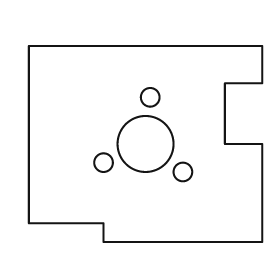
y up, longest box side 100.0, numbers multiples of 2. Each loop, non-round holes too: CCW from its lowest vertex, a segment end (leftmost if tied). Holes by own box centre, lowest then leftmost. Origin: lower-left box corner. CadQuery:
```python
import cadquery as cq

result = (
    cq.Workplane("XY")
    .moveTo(32.0, 0.0)
    .lineTo(100.0, 0.0)
    .lineTo(100.0, 42.0)
    .lineTo(84.0, 42.0)
    .lineTo(84.0, 68.0)
    .lineTo(100.0, 68.0)
    .lineTo(100.0, 84.0)
    .lineTo(0.0, 84.0)
    .lineTo(0.0, 8.0)
    .lineTo(32.0, 8.0)
    .close()
    .moveTo(66.0, 30.0)
    .circle(4.0)
    .moveTo(32.0, 34.0)
    .circle(4.0)
    .moveTo(50.0, 42.0)
    .circle(12.0)
    .moveTo(52.0, 62.0)
    .circle(4.0)
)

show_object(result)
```